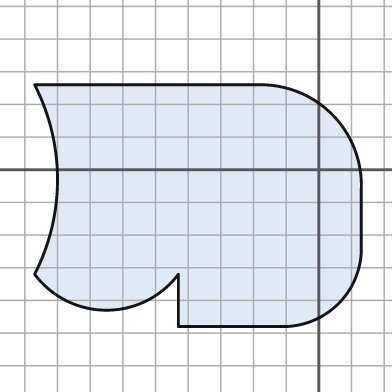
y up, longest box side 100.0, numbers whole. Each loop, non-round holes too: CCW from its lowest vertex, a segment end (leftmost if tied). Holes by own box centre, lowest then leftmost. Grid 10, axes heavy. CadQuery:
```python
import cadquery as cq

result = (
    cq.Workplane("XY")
    .moveTo(-43.0, -48.0)
    .lineTo(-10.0, -48.0)
    .threePointArc((6.0, -41.0), (13.0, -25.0))
    .lineTo(13.0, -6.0)
    .threePointArc((4.0, 17.0), (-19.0, 26.0))
    .lineTo(-87.0, 26.0)
    .threePointArc((-80.0, -3.0), (-87.0, -32.0))
    .threePointArc((-65.0, -43.0), (-43.0, -32.0))
    .close()
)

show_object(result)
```